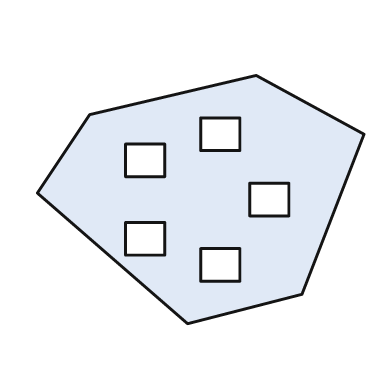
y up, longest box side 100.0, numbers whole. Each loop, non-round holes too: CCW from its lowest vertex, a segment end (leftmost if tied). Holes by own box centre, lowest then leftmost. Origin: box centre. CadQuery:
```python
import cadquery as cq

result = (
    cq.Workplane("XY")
    .moveTo(-4.0, -38.0)
    .lineTo(31.0, -29.0)
    .lineTo(50.0, 20.0)
    .lineTo(17.0, 38.0)
    .lineTo(-34.0, 26.0)
    .lineTo(-50.0, 2.0)
    .close()
    .moveTo(0.0, -25.0)
    .lineTo(12.0, -25.0)
    .lineTo(12.0, -15.0)
    .lineTo(0.0, -15.0)
    .close()
    .moveTo(-23.0, -17.0)
    .lineTo(-11.0, -17.0)
    .lineTo(-11.0, -7.0)
    .lineTo(-23.0, -7.0)
    .close()
    .moveTo(15.0, -5.0)
    .lineTo(27.0, -5.0)
    .lineTo(27.0, 5.0)
    .lineTo(15.0, 5.0)
    .close()
    .moveTo(-23.0, 7.0)
    .lineTo(-11.0, 7.0)
    .lineTo(-11.0, 17.0)
    .lineTo(-23.0, 17.0)
    .close()
    .moveTo(0.0, 15.0)
    .lineTo(12.0, 15.0)
    .lineTo(12.0, 25.0)
    .lineTo(0.0, 25.0)
    .close()
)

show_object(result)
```